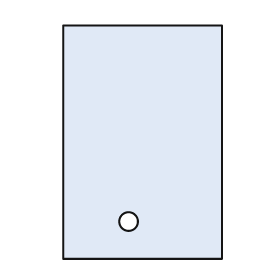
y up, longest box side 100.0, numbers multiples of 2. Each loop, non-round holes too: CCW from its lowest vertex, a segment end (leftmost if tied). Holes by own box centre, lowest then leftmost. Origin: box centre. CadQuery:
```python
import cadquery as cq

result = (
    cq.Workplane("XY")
    .moveTo(-34.0, -50.0)
    .lineTo(34.0, -50.0)
    .lineTo(34.0, 50.0)
    .lineTo(-34.0, 50.0)
    .close()
    .moveTo(-6.0, -34.0)
    .circle(4.0)
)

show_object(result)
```